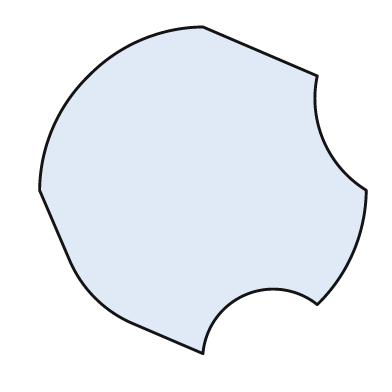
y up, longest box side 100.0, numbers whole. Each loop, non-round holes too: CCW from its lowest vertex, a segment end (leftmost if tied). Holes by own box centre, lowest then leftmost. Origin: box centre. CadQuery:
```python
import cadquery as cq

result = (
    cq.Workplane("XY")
    .moveTo(0.0, -50.0)
    .threePointArc((13.0, -32.0), (35.0, -35.0))
    .threePointArc((46.0, -19.0), (50.0, 0.0))
    .threePointArc((37.0, 15.0), (35.0, 35.0))
    .lineTo(0.0, 50.0)
    .threePointArc((-19.0, 46.0), (-35.0, 35.0))
    .threePointArc((-46.0, 19.0), (-50.0, 0.0))
    .lineTo(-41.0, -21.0)
    .threePointArc((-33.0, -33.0), (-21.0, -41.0))
    .close()
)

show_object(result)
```